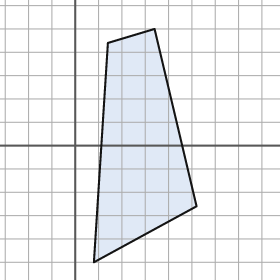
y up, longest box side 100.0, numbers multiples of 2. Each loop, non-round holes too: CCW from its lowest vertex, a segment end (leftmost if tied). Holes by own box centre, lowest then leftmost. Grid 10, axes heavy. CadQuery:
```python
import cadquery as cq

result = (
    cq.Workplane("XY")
    .moveTo(8.0, -50.0)
    .lineTo(52.0, -26.0)
    .lineTo(34.0, 50.0)
    .lineTo(14.0, 44.0)
    .close()
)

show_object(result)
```